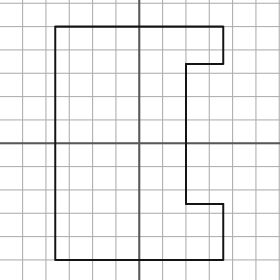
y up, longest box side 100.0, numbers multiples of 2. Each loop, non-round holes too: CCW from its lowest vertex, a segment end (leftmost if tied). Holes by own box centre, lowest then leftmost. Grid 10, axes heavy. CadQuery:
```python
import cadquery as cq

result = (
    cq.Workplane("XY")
    .moveTo(-36.0, -50.0)
    .lineTo(36.0, -50.0)
    .lineTo(36.0, -26.0)
    .lineTo(20.0, -26.0)
    .lineTo(20.0, 34.0)
    .lineTo(36.0, 34.0)
    .lineTo(36.0, 50.0)
    .lineTo(-36.0, 50.0)
    .close()
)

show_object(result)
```